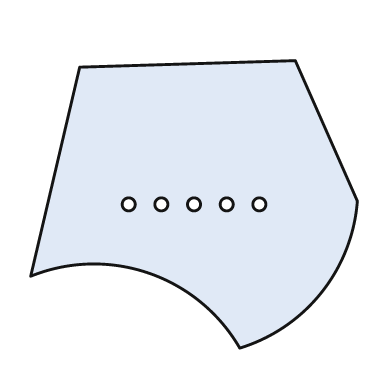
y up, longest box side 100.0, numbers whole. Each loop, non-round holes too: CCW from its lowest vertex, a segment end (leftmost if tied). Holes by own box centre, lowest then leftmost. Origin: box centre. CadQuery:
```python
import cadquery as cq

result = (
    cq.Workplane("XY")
    .moveTo(14.0, -44.0)
    .threePointArc((39.0, -27.0), (50.0, 1.0))
    .lineTo(31.0, 44.0)
    .lineTo(-35.0, 42.0)
    .lineTo(-50.0, -22.0)
    .threePointArc((-14.0, -21.0), (14.0, -44.0))
    .close()
    .moveTo(-20.0, 0.0)
    .circle(2.0)
    .moveTo(-10.0, 0.0)
    .circle(2.0)
    .moveTo(0.0, 0.0)
    .circle(2.0)
    .moveTo(10.0, 0.0)
    .circle(2.0)
    .moveTo(20.0, 0.0)
    .circle(2.0)
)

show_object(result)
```